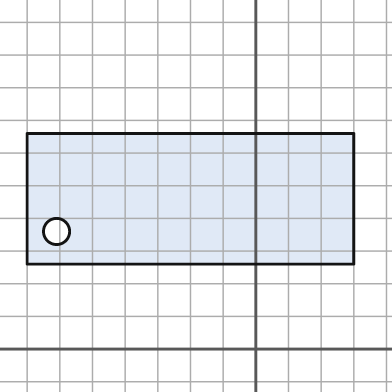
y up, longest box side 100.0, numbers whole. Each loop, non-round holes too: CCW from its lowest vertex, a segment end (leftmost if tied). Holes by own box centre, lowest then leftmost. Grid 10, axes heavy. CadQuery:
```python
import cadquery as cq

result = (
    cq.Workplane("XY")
    .moveTo(-70.0, 26.0)
    .lineTo(30.0, 26.0)
    .lineTo(30.0, 66.0)
    .lineTo(-70.0, 66.0)
    .close()
    .moveTo(-61.0, 36.0)
    .circle(4.0)
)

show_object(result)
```